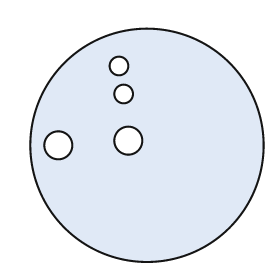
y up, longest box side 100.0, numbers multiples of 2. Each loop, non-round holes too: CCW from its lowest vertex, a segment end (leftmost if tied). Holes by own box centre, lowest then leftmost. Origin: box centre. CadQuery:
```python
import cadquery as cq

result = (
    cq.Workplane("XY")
    .moveTo(0.0, 0.0)
    .circle(50.0)
    .moveTo(-38.0, 0.0)
    .circle(6.0)
    .moveTo(-8.0, 2.0)
    .circle(6.0)
    .moveTo(-10.0, 22.0)
    .circle(4.0)
    .moveTo(-12.0, 34.0)
    .circle(4.0)
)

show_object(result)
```